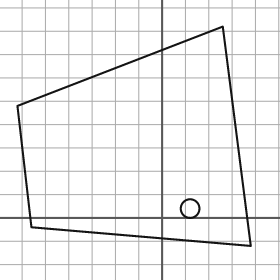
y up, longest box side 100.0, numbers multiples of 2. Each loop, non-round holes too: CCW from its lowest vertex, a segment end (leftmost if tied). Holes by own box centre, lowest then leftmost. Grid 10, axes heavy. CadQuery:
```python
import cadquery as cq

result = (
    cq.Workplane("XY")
    .moveTo(38.0, -12.0)
    .lineTo(26.0, 82.0)
    .lineTo(-62.0, 48.0)
    .lineTo(-56.0, -4.0)
    .close()
    .moveTo(12.0, 4.0)
    .circle(4.0)
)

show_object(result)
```